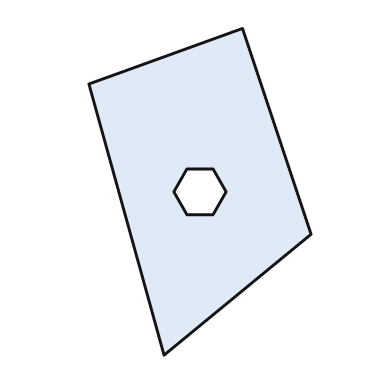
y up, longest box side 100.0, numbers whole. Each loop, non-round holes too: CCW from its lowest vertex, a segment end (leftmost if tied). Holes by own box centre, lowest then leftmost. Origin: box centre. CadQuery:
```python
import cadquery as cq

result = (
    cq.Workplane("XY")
    .moveTo(-11.0, -50.0)
    .lineTo(34.0, -13.0)
    .lineTo(13.0, 50.0)
    .lineTo(-34.0, 33.0)
    .close()
    .moveTo(-4.0, -7.0)
    .lineTo(4.0, -7.0)
    .lineTo(8.0, 0.0)
    .lineTo(4.0, 7.0)
    .lineTo(-4.0, 7.0)
    .lineTo(-8.0, 0.0)
    .close()
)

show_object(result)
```